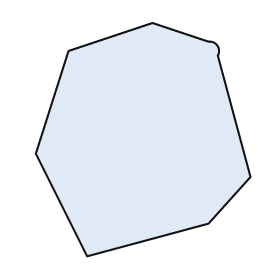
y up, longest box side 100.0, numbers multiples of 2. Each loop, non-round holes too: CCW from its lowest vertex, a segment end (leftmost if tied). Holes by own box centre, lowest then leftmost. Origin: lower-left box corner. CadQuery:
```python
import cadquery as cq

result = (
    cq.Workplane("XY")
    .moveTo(22.0, 0.0)
    .lineTo(74.0, 14.0)
    .lineTo(92.0, 34.0)
    .lineTo(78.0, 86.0)
    .threePointArc((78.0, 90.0), (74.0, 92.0))
    .lineTo(50.0, 100.0)
    .lineTo(14.0, 88.0)
    .lineTo(0.0, 44.0)
    .close()
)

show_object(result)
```